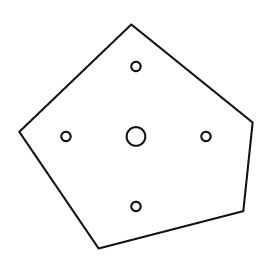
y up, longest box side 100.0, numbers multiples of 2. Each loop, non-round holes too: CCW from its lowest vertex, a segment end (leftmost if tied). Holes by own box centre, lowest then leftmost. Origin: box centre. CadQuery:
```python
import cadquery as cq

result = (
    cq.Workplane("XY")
    .moveTo(-16.0, -48.0)
    .lineTo(46.0, -32.0)
    .lineTo(50.0, 6.0)
    .lineTo(-2.0, 48.0)
    .lineTo(-50.0, 2.0)
    .close()
    .moveTo(0.0, -30.0)
    .circle(2.0)
    .moveTo(-30.0, 0.0)
    .circle(2.0)
    .moveTo(0.0, 0.0)
    .circle(4.0)
    .moveTo(30.0, 0.0)
    .circle(2.0)
    .moveTo(0.0, 30.0)
    .circle(2.0)
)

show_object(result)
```